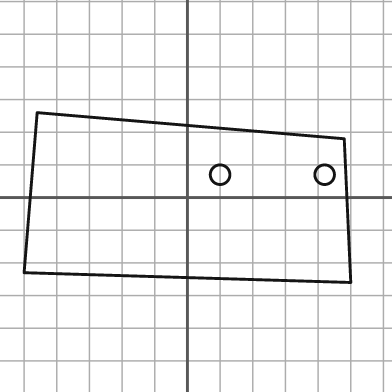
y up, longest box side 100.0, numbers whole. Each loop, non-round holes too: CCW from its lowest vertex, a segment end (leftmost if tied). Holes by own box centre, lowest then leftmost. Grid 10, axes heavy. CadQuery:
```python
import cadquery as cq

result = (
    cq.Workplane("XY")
    .moveTo(50.0, -26.0)
    .lineTo(48.0, 18.0)
    .lineTo(-46.0, 26.0)
    .lineTo(-50.0, -23.0)
    .close()
    .moveTo(10.0, 7.0)
    .circle(3.0)
    .moveTo(42.0, 7.0)
    .circle(3.0)
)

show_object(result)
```